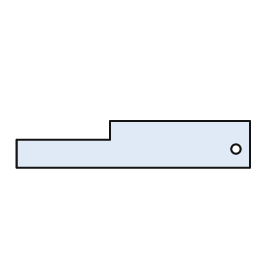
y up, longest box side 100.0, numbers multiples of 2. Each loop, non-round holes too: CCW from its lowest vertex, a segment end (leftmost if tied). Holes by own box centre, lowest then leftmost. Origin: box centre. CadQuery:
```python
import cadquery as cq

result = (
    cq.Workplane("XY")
    .moveTo(-50.0, -10.0)
    .lineTo(50.0, -10.0)
    .lineTo(50.0, 10.0)
    .lineTo(-10.0, 10.0)
    .lineTo(-10.0, 2.0)
    .lineTo(-50.0, 2.0)
    .close()
    .moveTo(44.0, -2.0)
    .circle(2.0)
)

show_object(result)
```